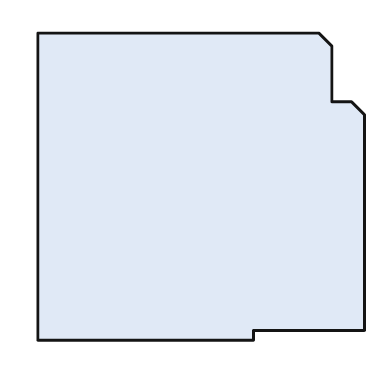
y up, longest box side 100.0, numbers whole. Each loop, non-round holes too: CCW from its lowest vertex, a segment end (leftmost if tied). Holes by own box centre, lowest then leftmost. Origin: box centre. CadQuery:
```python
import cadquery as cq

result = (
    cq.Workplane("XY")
    .moveTo(-50.0, -47.0)
    .lineTo(16.0, -47.0)
    .lineTo(16.0, -44.0)
    .lineTo(50.0, -44.0)
    .lineTo(50.0, 22.0)
    .lineTo(46.0, 26.0)
    .lineTo(40.0, 26.0)
    .lineTo(40.0, 43.0)
    .lineTo(36.0, 47.0)
    .lineTo(-50.0, 47.0)
    .close()
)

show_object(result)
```